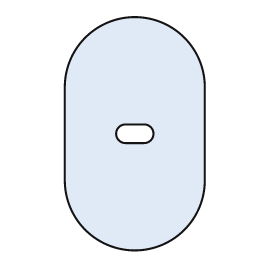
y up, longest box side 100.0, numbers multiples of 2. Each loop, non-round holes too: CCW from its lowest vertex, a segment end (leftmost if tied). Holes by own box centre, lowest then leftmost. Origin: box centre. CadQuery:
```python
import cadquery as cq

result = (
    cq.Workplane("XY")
    .moveTo(-30.0, -20.0)
    .threePointArc((0.0, -50.0), (30.0, -20.0))
    .lineTo(30.0, 20.0)
    .threePointArc((0.0, 50.0), (-30.0, 20.0))
    .close()
    .moveTo(-4.0, -4.0)
    .lineTo(4.0, -4.0)
    .threePointArc((8.0, 0.0), (4.0, 4.0))
    .lineTo(-4.0, 4.0)
    .threePointArc((-8.0, 0.0), (-4.0, -4.0))
    .close()
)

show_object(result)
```